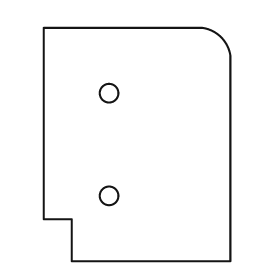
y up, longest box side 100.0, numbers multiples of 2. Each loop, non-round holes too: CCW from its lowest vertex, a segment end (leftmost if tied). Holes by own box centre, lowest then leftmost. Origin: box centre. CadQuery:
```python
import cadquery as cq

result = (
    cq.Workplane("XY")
    .moveTo(-28.0, -50.0)
    .lineTo(40.0, -50.0)
    .lineTo(40.0, 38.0)
    .threePointArc((36.0, 46.0), (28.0, 50.0))
    .lineTo(-40.0, 50.0)
    .lineTo(-40.0, -32.0)
    .lineTo(-28.0, -32.0)
    .close()
    .moveTo(-12.0, -22.0)
    .circle(4.0)
    .moveTo(-12.0, 22.0)
    .circle(4.0)
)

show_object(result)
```